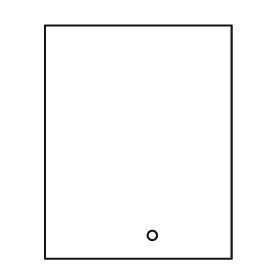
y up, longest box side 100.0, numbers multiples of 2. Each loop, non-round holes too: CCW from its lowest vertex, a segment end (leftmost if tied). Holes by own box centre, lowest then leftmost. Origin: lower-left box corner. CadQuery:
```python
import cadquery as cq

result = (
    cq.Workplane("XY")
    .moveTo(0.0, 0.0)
    .lineTo(80.0, 0.0)
    .lineTo(80.0, 100.0)
    .lineTo(0.0, 100.0)
    .close()
    .moveTo(46.0, 10.0)
    .circle(2.0)
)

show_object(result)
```